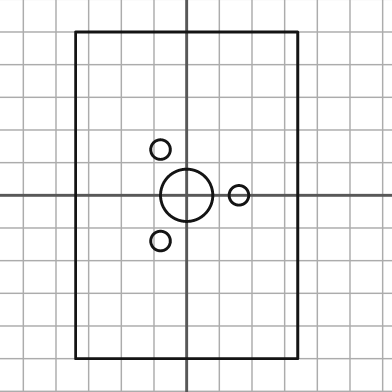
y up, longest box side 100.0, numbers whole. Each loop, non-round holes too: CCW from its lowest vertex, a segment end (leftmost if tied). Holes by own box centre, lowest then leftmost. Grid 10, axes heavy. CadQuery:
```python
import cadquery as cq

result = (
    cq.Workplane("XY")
    .moveTo(-34.0, -50.0)
    .lineTo(34.0, -50.0)
    .lineTo(34.0, 50.0)
    .lineTo(-34.0, 50.0)
    .close()
    .moveTo(-8.0, -14.0)
    .circle(3.0)
    .moveTo(0.0, 0.0)
    .circle(8.0)
    .moveTo(16.0, 0.0)
    .circle(3.0)
    .moveTo(-8.0, 14.0)
    .circle(3.0)
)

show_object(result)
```